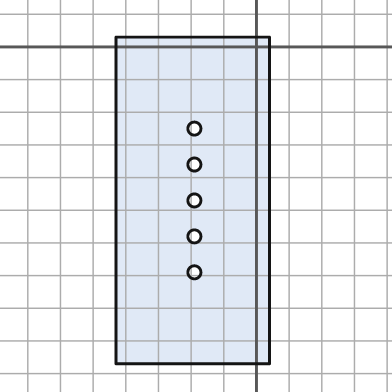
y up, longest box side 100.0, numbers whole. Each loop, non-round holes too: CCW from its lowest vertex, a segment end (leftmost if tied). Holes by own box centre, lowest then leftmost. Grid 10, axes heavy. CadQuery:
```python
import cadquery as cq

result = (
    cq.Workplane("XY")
    .moveTo(-43.0, -97.0)
    .lineTo(4.0, -97.0)
    .lineTo(4.0, 3.0)
    .lineTo(-43.0, 3.0)
    .close()
    .moveTo(-19.0, -69.0)
    .circle(2.0)
    .moveTo(-19.0, -58.0)
    .circle(2.0)
    .moveTo(-19.0, -47.0)
    .circle(2.0)
    .moveTo(-19.0, -36.0)
    .circle(2.0)
    .moveTo(-19.0, -25.0)
    .circle(2.0)
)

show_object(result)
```